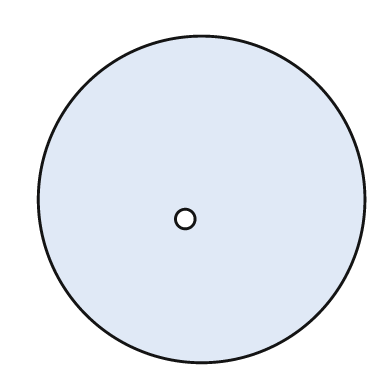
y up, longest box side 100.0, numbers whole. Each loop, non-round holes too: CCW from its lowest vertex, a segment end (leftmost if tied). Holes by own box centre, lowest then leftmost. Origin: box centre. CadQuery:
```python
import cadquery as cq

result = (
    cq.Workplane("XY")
    .moveTo(0.0, 0.0)
    .circle(50.0)
    .moveTo(-5.0, -6.0)
    .circle(3.0)
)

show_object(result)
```